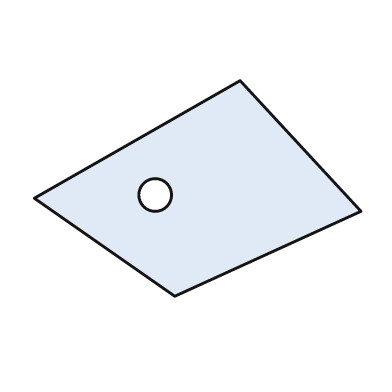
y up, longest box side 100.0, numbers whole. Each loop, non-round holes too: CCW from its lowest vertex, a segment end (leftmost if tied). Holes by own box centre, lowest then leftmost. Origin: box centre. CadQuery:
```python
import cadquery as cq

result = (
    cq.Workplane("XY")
    .moveTo(-7.0, -33.0)
    .lineTo(50.0, -7.0)
    .lineTo(13.0, 33.0)
    .lineTo(-50.0, -3.0)
    .close()
    .moveTo(-13.0, -2.0)
    .circle(5.0)
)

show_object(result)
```